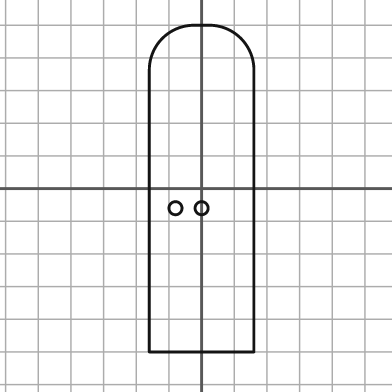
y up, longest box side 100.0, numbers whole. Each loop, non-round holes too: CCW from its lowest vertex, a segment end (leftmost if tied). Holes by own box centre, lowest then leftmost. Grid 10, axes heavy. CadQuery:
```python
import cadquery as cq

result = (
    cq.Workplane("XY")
    .moveTo(-16.0, -50.0)
    .lineTo(16.0, -50.0)
    .lineTo(16.0, 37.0)
    .threePointArc((12.0, 46.0), (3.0, 50.0))
    .lineTo(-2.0, 50.0)
    .threePointArc((-12.0, 46.0), (-16.0, 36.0))
    .close()
    .moveTo(-8.0, -6.0)
    .circle(2.0)
    .moveTo(0.0, -6.0)
    .circle(2.0)
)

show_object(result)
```